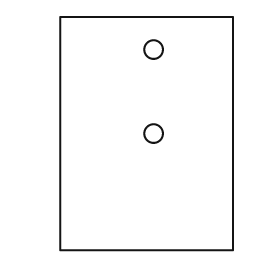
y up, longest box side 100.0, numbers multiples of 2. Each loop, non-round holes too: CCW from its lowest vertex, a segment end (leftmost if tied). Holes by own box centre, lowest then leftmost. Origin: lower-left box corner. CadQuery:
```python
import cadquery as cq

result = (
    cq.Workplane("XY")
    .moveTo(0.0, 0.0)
    .lineTo(74.0, 0.0)
    .lineTo(74.0, 100.0)
    .lineTo(0.0, 100.0)
    .close()
    .moveTo(40.0, 50.0)
    .circle(4.0)
    .moveTo(40.0, 86.0)
    .circle(4.0)
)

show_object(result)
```